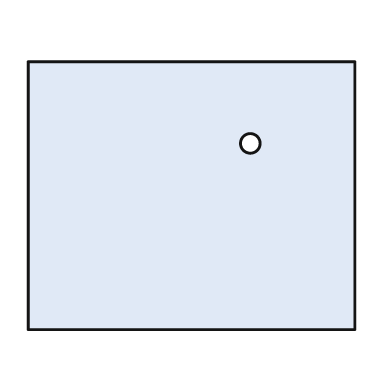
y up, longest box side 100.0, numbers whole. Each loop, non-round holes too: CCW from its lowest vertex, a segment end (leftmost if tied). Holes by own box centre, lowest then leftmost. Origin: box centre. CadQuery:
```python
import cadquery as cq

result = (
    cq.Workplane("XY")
    .moveTo(-50.0, -41.0)
    .lineTo(50.0, -41.0)
    .lineTo(50.0, 41.0)
    .lineTo(-50.0, 41.0)
    .close()
    .moveTo(18.0, 16.0)
    .circle(3.0)
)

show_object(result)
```